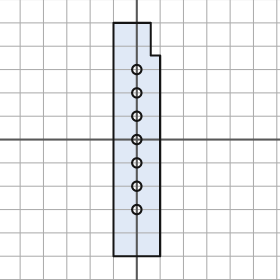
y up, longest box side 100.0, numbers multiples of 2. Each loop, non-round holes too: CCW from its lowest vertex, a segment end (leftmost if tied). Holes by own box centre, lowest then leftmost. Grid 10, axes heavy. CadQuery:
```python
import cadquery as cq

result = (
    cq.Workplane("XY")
    .moveTo(-10.0, -50.0)
    .lineTo(10.0, -50.0)
    .lineTo(10.0, 36.0)
    .lineTo(6.0, 36.0)
    .lineTo(6.0, 50.0)
    .lineTo(-10.0, 50.0)
    .close()
    .moveTo(0.0, -30.0)
    .circle(2.0)
    .moveTo(0.0, -20.0)
    .circle(2.0)
    .moveTo(0.0, -10.0)
    .circle(2.0)
    .moveTo(0.0, 0.0)
    .circle(2.0)
    .moveTo(0.0, 10.0)
    .circle(2.0)
    .moveTo(0.0, 20.0)
    .circle(2.0)
    .moveTo(0.0, 30.0)
    .circle(2.0)
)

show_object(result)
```